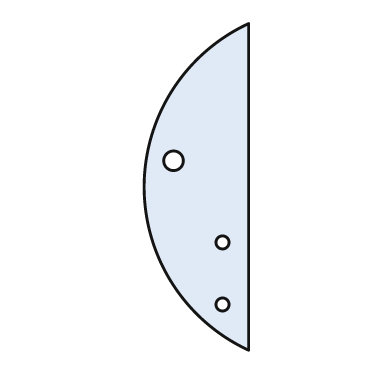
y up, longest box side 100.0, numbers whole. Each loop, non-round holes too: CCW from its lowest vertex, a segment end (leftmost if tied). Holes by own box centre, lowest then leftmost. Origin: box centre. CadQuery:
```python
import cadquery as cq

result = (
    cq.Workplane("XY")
    .moveTo(16.0, -50.0)
    .lineTo(16.0, 50.0)
    .threePointArc((-16.0, 0.0), (16.0, -50.0))
    .close()
    .moveTo(8.0, -36.0)
    .circle(2.0)
    .moveTo(8.0, -17.0)
    .circle(2.0)
    .moveTo(-7.0, 8.0)
    .circle(3.0)
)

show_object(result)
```